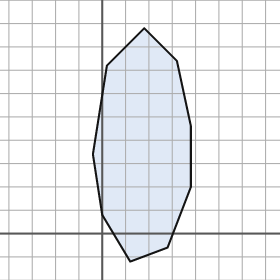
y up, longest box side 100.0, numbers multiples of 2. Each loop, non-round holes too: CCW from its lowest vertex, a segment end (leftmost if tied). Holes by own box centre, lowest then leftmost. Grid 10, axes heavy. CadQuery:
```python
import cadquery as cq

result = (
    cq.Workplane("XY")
    .moveTo(12.0, -12.0)
    .lineTo(28.0, -6.0)
    .lineTo(38.0, 20.0)
    .lineTo(38.0, 46.0)
    .lineTo(32.0, 74.0)
    .lineTo(18.0, 88.0)
    .lineTo(2.0, 72.0)
    .lineTo(-4.0, 34.0)
    .lineTo(0.0, 8.0)
    .close()
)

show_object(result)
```